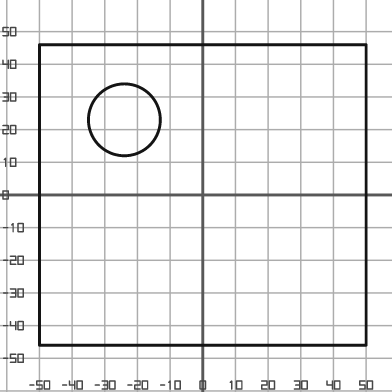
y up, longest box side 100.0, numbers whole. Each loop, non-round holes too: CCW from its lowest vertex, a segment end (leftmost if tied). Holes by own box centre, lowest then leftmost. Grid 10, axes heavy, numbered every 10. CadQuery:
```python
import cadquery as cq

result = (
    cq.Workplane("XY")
    .moveTo(-50.0, -46.0)
    .lineTo(50.0, -46.0)
    .lineTo(50.0, 46.0)
    .lineTo(-50.0, 46.0)
    .close()
    .moveTo(-24.0, 23.0)
    .circle(11.0)
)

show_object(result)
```